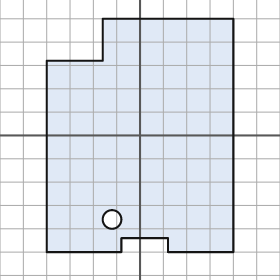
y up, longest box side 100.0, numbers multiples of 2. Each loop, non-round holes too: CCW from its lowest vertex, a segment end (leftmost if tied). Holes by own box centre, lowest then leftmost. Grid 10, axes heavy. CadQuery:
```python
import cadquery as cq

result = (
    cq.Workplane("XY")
    .moveTo(-40.0, -50.0)
    .lineTo(-8.0, -50.0)
    .lineTo(-8.0, -44.0)
    .lineTo(12.0, -44.0)
    .lineTo(12.0, -50.0)
    .lineTo(40.0, -50.0)
    .lineTo(40.0, 50.0)
    .lineTo(-16.0, 50.0)
    .lineTo(-16.0, 32.0)
    .lineTo(-40.0, 32.0)
    .close()
    .moveTo(-12.0, -36.0)
    .circle(4.0)
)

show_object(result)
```